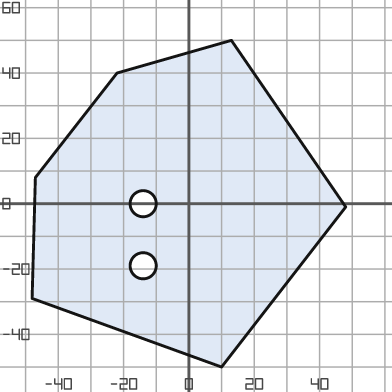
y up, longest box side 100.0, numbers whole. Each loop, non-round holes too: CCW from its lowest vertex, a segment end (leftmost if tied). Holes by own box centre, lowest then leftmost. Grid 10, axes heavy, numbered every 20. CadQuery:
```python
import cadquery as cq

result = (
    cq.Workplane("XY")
    .moveTo(10.0, -50.0)
    .lineTo(48.0, -1.0)
    .lineTo(13.0, 50.0)
    .lineTo(-22.0, 40.0)
    .lineTo(-47.0, 8.0)
    .lineTo(-48.0, -29.0)
    .close()
    .moveTo(-14.0, -19.0)
    .circle(4.0)
    .moveTo(-14.0, 0.0)
    .circle(4.0)
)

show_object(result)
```